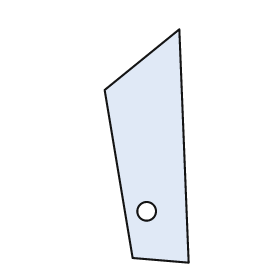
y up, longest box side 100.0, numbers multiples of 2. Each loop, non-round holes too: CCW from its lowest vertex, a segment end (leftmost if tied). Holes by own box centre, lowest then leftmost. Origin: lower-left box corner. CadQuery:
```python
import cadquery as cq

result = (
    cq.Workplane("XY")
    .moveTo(36.0, 0.0)
    .lineTo(32.0, 100.0)
    .lineTo(0.0, 74.0)
    .lineTo(12.0, 2.0)
    .close()
    .moveTo(18.0, 22.0)
    .circle(4.0)
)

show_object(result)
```